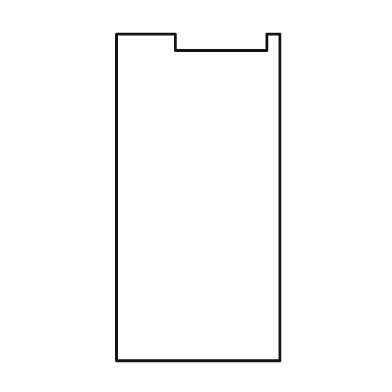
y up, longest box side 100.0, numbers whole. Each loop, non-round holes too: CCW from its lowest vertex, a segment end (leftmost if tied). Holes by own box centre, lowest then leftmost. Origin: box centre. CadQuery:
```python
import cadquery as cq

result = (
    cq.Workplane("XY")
    .moveTo(-25.0, -50.0)
    .lineTo(25.0, -50.0)
    .lineTo(25.0, 50.0)
    .lineTo(21.0, 50.0)
    .lineTo(21.0, 45.0)
    .lineTo(-7.0, 45.0)
    .lineTo(-7.0, 50.0)
    .lineTo(-25.0, 50.0)
    .close()
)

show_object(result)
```